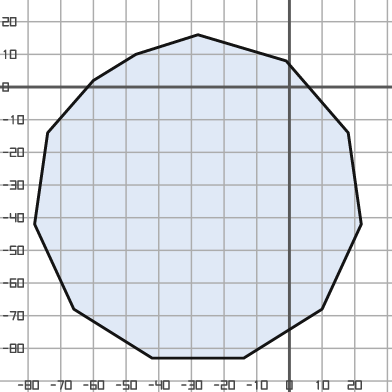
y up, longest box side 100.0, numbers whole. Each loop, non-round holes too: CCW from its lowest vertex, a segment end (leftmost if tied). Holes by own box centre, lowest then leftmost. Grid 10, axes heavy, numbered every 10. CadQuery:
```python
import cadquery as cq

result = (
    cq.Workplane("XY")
    .moveTo(-42.0, -83.0)
    .lineTo(-14.0, -83.0)
    .lineTo(10.0, -68.0)
    .lineTo(22.0, -42.0)
    .lineTo(18.0, -14.0)
    .lineTo(-1.0, 8.0)
    .lineTo(-28.0, 16.0)
    .lineTo(-47.0, 10.0)
    .lineTo(-60.0, 2.0)
    .lineTo(-74.0, -14.0)
    .lineTo(-78.0, -42.0)
    .lineTo(-66.0, -68.0)
    .close()
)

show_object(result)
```